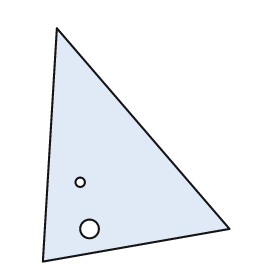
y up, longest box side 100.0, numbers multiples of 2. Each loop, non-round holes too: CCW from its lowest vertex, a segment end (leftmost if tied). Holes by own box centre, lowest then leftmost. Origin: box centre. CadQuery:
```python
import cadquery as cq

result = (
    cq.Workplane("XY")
    .moveTo(-40.0, -50.0)
    .lineTo(40.0, -36.0)
    .lineTo(-34.0, 50.0)
    .close()
    .moveTo(-20.0, -36.0)
    .circle(4.0)
    .moveTo(-24.0, -16.0)
    .circle(2.0)
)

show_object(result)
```